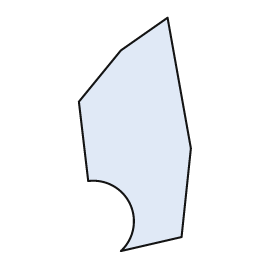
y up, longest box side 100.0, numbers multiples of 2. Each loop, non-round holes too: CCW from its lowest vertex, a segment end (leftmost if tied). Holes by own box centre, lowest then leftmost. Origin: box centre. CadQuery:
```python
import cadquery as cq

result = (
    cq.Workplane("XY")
    .moveTo(-6.0, -50.0)
    .lineTo(20.0, -44.0)
    .lineTo(24.0, -6.0)
    .lineTo(14.0, 50.0)
    .lineTo(-6.0, 36.0)
    .lineTo(-24.0, 14.0)
    .lineTo(-20.0, -20.0)
    .threePointArc((-2.0, -30.0), (-6.0, -50.0))
    .close()
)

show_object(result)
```